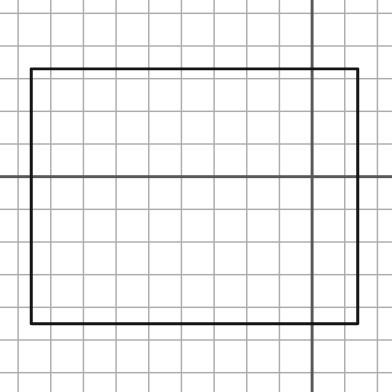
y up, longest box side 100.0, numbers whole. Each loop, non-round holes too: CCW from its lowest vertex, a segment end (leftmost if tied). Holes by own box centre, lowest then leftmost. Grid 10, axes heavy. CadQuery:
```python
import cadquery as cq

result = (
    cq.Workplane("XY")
    .moveTo(-86.0, -45.0)
    .lineTo(14.0, -45.0)
    .lineTo(14.0, 33.0)
    .lineTo(-86.0, 33.0)
    .close()
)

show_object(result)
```